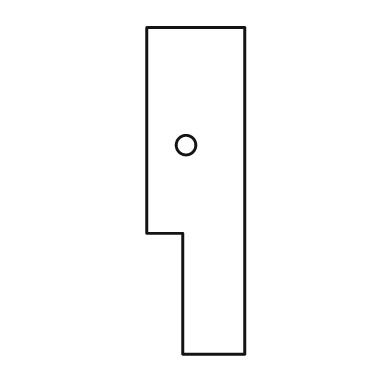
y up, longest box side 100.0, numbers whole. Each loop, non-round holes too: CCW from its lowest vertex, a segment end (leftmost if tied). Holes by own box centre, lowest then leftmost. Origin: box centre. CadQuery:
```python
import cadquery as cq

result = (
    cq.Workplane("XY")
    .moveTo(-4.0, -50.0)
    .lineTo(15.0, -50.0)
    .lineTo(15.0, 50.0)
    .lineTo(-15.0, 50.0)
    .lineTo(-15.0, -13.0)
    .lineTo(-4.0, -13.0)
    .close()
    .moveTo(-3.0, 14.0)
    .circle(3.0)
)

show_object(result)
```